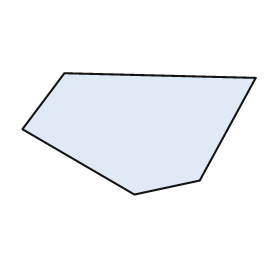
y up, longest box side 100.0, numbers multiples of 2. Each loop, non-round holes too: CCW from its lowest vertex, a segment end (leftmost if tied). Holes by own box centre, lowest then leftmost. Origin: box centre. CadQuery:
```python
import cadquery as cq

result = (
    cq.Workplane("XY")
    .moveTo(-2.0, -26.0)
    .lineTo(26.0, -20.0)
    .lineTo(50.0, 24.0)
    .lineTo(-32.0, 26.0)
    .lineTo(-50.0, 2.0)
    .close()
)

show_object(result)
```